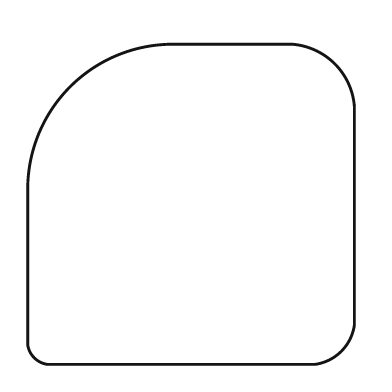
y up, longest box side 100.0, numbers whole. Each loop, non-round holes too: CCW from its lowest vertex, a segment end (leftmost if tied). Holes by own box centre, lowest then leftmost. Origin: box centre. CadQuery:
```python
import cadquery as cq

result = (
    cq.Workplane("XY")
    .moveTo(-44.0, -49.0)
    .lineTo(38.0, -49.0)
    .threePointArc((46.0, -45.0), (50.0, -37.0))
    .lineTo(50.0, 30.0)
    .threePointArc((44.0, 43.0), (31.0, 49.0))
    .lineTo(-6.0, 49.0)
    .threePointArc((-37.0, 36.0), (-50.0, 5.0))
    .lineTo(-50.0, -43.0)
    .threePointArc((-48.0, -47.0), (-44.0, -49.0))
    .close()
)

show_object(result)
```